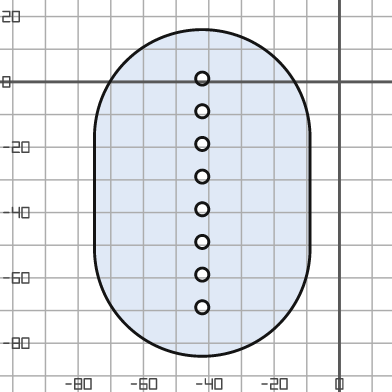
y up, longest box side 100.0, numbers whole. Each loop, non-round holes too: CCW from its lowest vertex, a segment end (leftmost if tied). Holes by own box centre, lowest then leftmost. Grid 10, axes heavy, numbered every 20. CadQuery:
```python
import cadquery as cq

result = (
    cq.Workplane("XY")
    .moveTo(-75.0, -51.0)
    .threePointArc((-42.0, -84.0), (-9.0, -51.0))
    .lineTo(-9.0, -17.0)
    .threePointArc((-42.0, 16.0), (-75.0, -17.0))
    .close()
    .moveTo(-42.0, -69.0)
    .circle(2.0)
    .moveTo(-42.0, -59.0)
    .circle(2.0)
    .moveTo(-42.0, -49.0)
    .circle(2.0)
    .moveTo(-42.0, -39.0)
    .circle(2.0)
    .moveTo(-42.0, -29.0)
    .circle(2.0)
    .moveTo(-42.0, -19.0)
    .circle(2.0)
    .moveTo(-42.0, -9.0)
    .circle(2.0)
    .moveTo(-42.0, 1.0)
    .circle(2.0)
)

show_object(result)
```